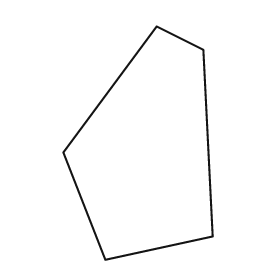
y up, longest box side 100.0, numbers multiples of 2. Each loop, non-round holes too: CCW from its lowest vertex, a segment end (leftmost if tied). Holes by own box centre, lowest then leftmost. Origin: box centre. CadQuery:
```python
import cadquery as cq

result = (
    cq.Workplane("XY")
    .moveTo(-14.0, -50.0)
    .lineTo(32.0, -40.0)
    .lineTo(28.0, 40.0)
    .lineTo(8.0, 50.0)
    .lineTo(-32.0, -4.0)
    .close()
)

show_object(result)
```